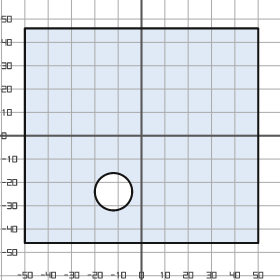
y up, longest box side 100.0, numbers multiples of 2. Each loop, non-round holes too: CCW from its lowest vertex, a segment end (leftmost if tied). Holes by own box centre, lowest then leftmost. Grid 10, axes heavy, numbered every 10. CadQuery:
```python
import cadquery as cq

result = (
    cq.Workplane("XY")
    .moveTo(-50.0, -46.0)
    .lineTo(50.0, -46.0)
    .lineTo(50.0, 46.0)
    .lineTo(-50.0, 46.0)
    .close()
    .moveTo(-12.0, -24.0)
    .circle(8.0)
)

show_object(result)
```